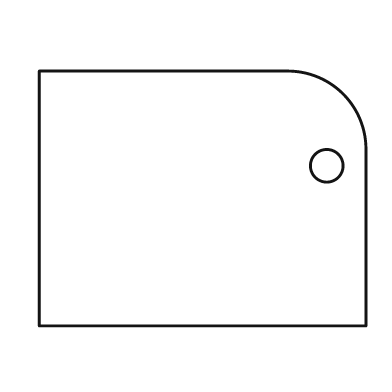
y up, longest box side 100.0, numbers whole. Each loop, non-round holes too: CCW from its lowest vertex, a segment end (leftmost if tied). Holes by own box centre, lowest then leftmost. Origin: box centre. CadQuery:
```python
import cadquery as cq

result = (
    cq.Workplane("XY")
    .moveTo(-50.0, -39.0)
    .lineTo(50.0, -39.0)
    .lineTo(50.0, 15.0)
    .threePointArc((43.0, 32.0), (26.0, 39.0))
    .lineTo(-50.0, 39.0)
    .close()
    .moveTo(38.0, 10.0)
    .circle(5.0)
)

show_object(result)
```